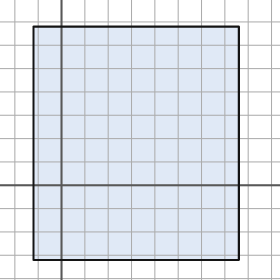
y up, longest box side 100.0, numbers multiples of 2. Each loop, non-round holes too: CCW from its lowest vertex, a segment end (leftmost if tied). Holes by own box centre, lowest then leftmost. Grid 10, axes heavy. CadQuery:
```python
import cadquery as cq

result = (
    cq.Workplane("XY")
    .moveTo(-12.0, -32.0)
    .lineTo(76.0, -32.0)
    .lineTo(76.0, 68.0)
    .lineTo(-12.0, 68.0)
    .close()
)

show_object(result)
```